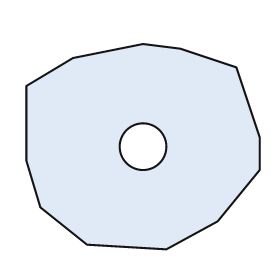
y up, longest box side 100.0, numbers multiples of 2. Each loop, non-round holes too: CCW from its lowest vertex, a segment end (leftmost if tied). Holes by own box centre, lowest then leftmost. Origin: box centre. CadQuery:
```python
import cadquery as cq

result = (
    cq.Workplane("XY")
    .moveTo(10.0, -44.0)
    .lineTo(32.0, -32.0)
    .lineTo(50.0, -10.0)
    .lineTo(50.0, 4.0)
    .lineTo(40.0, 34.0)
    .lineTo(16.0, 42.0)
    .lineTo(0.0, 44.0)
    .lineTo(-30.0, 38.0)
    .lineTo(-50.0, 26.0)
    .lineTo(-50.0, -6.0)
    .lineTo(-44.0, -26.0)
    .lineTo(-24.0, -42.0)
    .close()
    .moveTo(0.0, 0.0)
    .circle(10.0)
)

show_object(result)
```